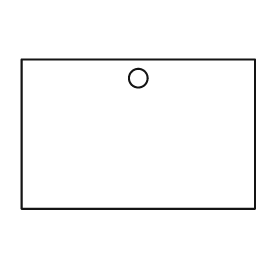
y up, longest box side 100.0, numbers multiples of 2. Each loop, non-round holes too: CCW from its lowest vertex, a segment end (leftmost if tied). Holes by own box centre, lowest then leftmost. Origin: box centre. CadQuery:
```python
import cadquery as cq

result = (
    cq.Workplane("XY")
    .moveTo(-50.0, -32.0)
    .lineTo(50.0, -32.0)
    .lineTo(50.0, 32.0)
    .lineTo(-50.0, 32.0)
    .close()
    .moveTo(0.0, 24.0)
    .circle(4.0)
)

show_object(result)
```